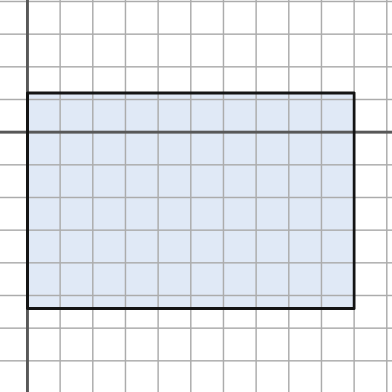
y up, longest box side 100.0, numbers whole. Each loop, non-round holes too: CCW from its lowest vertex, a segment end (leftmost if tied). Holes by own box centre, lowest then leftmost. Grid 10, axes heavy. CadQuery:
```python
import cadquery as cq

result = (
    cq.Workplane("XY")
    .moveTo(0.0, -54.0)
    .lineTo(100.0, -54.0)
    .lineTo(100.0, 12.0)
    .lineTo(0.0, 12.0)
    .close()
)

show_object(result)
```